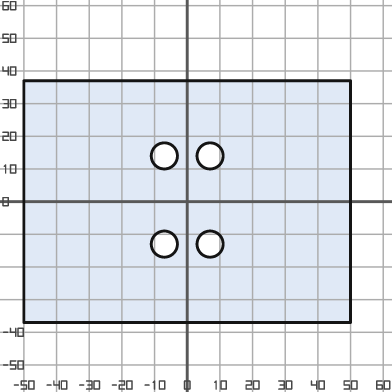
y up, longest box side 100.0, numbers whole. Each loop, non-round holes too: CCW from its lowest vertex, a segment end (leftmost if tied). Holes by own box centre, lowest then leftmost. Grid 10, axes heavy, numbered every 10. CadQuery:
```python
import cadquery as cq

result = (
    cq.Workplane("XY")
    .moveTo(-50.0, -37.0)
    .lineTo(50.0, -37.0)
    .lineTo(50.0, 37.0)
    .lineTo(-50.0, 37.0)
    .close()
    .moveTo(-7.0, -13.0)
    .circle(4.0)
    .moveTo(7.0, -13.0)
    .circle(4.0)
    .moveTo(-7.0, 14.0)
    .circle(4.0)
    .moveTo(7.0, 14.0)
    .circle(4.0)
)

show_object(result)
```